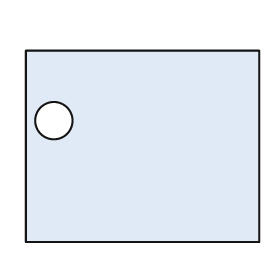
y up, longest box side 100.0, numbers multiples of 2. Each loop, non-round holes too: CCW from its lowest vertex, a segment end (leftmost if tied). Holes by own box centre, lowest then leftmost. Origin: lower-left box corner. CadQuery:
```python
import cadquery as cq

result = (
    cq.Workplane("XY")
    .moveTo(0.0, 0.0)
    .lineTo(100.0, 0.0)
    .lineTo(100.0, 82.0)
    .lineTo(0.0, 82.0)
    .close()
    .moveTo(12.0, 52.0)
    .circle(8.0)
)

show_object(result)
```